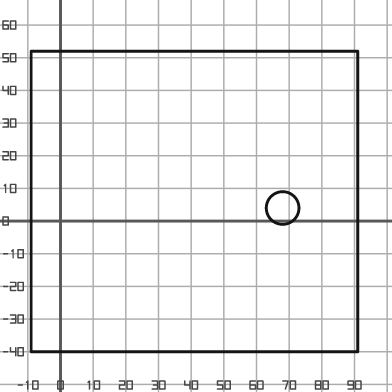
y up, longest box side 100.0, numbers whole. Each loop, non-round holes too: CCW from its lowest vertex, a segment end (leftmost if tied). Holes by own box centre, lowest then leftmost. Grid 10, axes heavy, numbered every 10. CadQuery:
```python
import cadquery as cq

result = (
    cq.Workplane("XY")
    .moveTo(-9.0, -40.0)
    .lineTo(91.0, -40.0)
    .lineTo(91.0, 52.0)
    .lineTo(-9.0, 52.0)
    .close()
    .moveTo(68.0, 4.0)
    .circle(5.0)
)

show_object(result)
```